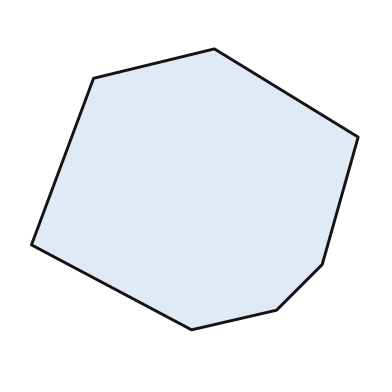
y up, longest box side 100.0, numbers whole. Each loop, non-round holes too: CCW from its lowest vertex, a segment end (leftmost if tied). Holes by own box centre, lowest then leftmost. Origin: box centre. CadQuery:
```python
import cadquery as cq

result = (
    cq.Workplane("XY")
    .moveTo(-1.0, -43.0)
    .lineTo(25.0, -37.0)
    .lineTo(39.0, -23.0)
    .lineTo(50.0, 16.0)
    .lineTo(6.0, 43.0)
    .lineTo(-31.0, 34.0)
    .lineTo(-50.0, -17.0)
    .close()
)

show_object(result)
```